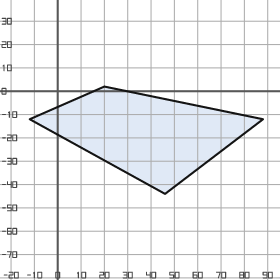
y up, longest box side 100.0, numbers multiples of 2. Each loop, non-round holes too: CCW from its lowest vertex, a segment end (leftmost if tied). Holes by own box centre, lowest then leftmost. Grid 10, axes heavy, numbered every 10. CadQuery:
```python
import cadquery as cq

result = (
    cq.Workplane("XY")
    .moveTo(46.0, -44.0)
    .lineTo(88.0, -12.0)
    .lineTo(20.0, 2.0)
    .lineTo(-12.0, -12.0)
    .close()
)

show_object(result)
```